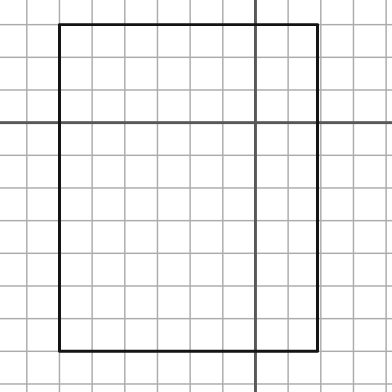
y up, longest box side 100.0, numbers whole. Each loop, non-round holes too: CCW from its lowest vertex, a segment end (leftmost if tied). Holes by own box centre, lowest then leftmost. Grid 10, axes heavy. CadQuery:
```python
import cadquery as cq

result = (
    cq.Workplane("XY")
    .moveTo(-60.0, -70.0)
    .lineTo(19.0, -70.0)
    .lineTo(19.0, 30.0)
    .lineTo(-60.0, 30.0)
    .close()
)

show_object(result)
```